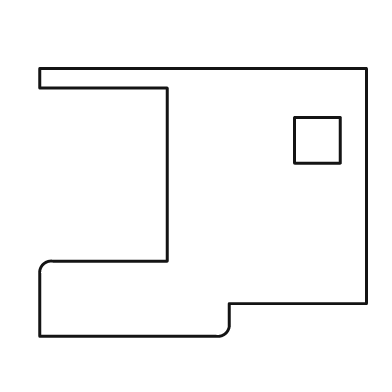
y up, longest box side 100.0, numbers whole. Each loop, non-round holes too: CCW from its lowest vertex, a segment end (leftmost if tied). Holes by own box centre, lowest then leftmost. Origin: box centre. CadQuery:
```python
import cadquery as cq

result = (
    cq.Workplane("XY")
    .moveTo(-50.0, -41.0)
    .lineTo(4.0, -41.0)
    .threePointArc((7.0, -40.0), (8.0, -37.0))
    .lineTo(8.0, -31.0)
    .lineTo(50.0, -31.0)
    .lineTo(50.0, 41.0)
    .lineTo(-50.0, 41.0)
    .lineTo(-50.0, 35.0)
    .lineTo(-11.0, 35.0)
    .lineTo(-11.0, -18.0)
    .lineTo(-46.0, -18.0)
    .threePointArc((-49.0, -19.0), (-50.0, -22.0))
    .close()
    .moveTo(28.0, 12.0)
    .lineTo(42.0, 12.0)
    .lineTo(42.0, 26.0)
    .lineTo(28.0, 26.0)
    .close()
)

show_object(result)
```